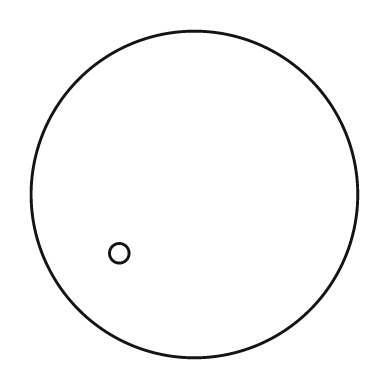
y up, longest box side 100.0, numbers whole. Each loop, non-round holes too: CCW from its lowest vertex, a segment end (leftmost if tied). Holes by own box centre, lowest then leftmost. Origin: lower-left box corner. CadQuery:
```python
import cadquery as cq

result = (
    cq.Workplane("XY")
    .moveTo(50.0, 50.0)
    .circle(50.0)
    .moveTo(27.0, 32.0)
    .circle(3.0)
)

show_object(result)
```